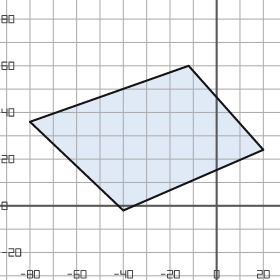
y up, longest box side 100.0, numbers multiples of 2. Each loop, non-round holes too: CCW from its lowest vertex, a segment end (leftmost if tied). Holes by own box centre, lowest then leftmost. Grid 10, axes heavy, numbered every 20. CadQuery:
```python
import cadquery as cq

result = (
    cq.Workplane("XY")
    .moveTo(-40.0, -2.0)
    .lineTo(20.0, 24.0)
    .lineTo(-12.0, 60.0)
    .lineTo(-80.0, 36.0)
    .close()
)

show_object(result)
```